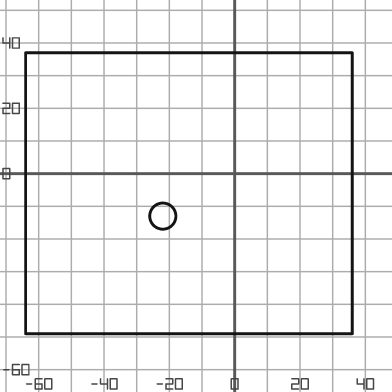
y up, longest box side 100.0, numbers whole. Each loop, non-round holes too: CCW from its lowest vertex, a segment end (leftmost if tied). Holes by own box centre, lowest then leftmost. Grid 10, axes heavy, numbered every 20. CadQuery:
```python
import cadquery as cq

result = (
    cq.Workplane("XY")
    .moveTo(-64.0, -49.0)
    .lineTo(36.0, -49.0)
    .lineTo(36.0, 37.0)
    .lineTo(-64.0, 37.0)
    .close()
    .moveTo(-22.0, -13.0)
    .circle(4.0)
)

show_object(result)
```